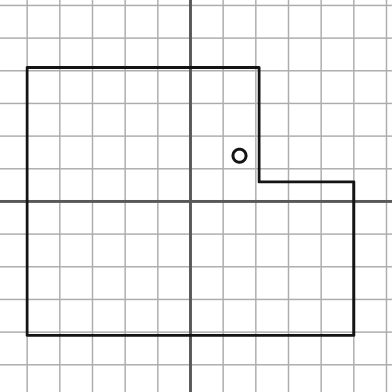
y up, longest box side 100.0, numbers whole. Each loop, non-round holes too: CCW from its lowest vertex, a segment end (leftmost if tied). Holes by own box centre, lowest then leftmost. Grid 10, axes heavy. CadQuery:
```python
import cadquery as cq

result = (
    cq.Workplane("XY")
    .moveTo(-50.0, -41.0)
    .lineTo(50.0, -41.0)
    .lineTo(50.0, 6.0)
    .lineTo(21.0, 6.0)
    .lineTo(21.0, 41.0)
    .lineTo(-50.0, 41.0)
    .close()
    .moveTo(15.0, 14.0)
    .circle(2.0)
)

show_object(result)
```